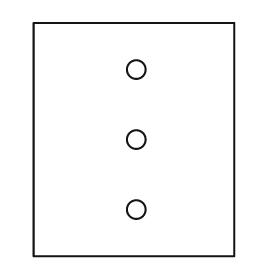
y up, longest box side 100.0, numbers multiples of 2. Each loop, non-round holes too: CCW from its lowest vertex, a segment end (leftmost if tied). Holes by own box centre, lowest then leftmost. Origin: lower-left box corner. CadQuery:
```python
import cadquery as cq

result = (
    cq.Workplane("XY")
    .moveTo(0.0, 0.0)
    .lineTo(86.0, 0.0)
    .lineTo(86.0, 100.0)
    .lineTo(0.0, 100.0)
    .close()
    .moveTo(44.0, 20.0)
    .circle(4.0)
    .moveTo(44.0, 50.0)
    .circle(4.0)
    .moveTo(44.0, 80.0)
    .circle(4.0)
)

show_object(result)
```